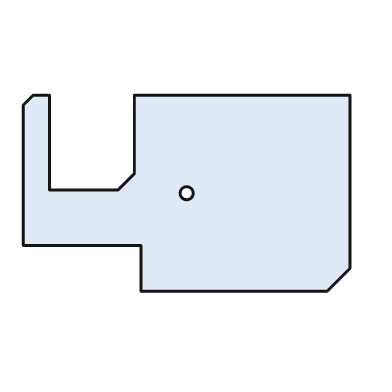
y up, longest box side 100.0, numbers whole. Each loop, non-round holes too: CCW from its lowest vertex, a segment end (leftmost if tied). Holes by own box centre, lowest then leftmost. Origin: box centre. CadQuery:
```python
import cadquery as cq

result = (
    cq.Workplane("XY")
    .moveTo(-14.0, -30.0)
    .lineTo(43.0, -30.0)
    .lineTo(50.0, -23.0)
    .lineTo(50.0, 30.0)
    .lineTo(-16.0, 30.0)
    .lineTo(-16.0, 6.0)
    .lineTo(-21.0, 1.0)
    .lineTo(-42.0, 1.0)
    .lineTo(-42.0, 30.0)
    .lineTo(-47.0, 30.0)
    .lineTo(-50.0, 27.0)
    .lineTo(-50.0, -16.0)
    .lineTo(-14.0, -16.0)
    .close()
    .moveTo(0.0, 0.0)
    .circle(2.0)
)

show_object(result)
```